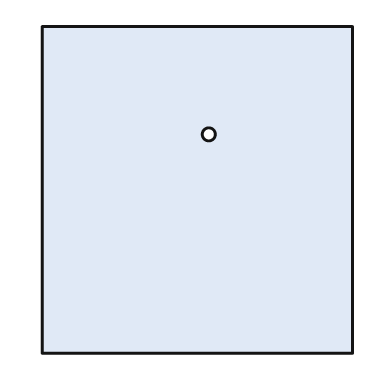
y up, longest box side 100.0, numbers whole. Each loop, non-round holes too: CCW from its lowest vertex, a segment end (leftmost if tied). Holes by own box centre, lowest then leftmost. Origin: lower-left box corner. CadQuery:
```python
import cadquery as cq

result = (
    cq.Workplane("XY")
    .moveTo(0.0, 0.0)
    .lineTo(95.0, 0.0)
    .lineTo(95.0, 100.0)
    .lineTo(0.0, 100.0)
    .close()
    .moveTo(51.0, 67.0)
    .circle(2.0)
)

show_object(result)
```